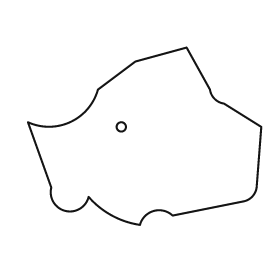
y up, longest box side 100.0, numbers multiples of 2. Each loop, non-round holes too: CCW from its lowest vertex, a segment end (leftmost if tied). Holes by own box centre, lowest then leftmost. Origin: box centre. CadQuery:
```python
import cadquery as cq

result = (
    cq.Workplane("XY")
    .moveTo(-2.0, -38.0)
    .threePointArc((4.0, -32.0), (12.0, -34.0))
    .lineTo(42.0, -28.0)
    .threePointArc((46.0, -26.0), (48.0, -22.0))
    .lineTo(50.0, 4.0)
    .lineTo(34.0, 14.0)
    .threePointArc((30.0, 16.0), (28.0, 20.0))
    .lineTo(18.0, 38.0)
    .lineTo(-4.0, 32.0)
    .lineTo(-20.0, 20.0)
    .threePointArc((-32.0, 6.0), (-50.0, 6.0))
    .lineTo(-40.0, -22.0)
    .threePointArc((-34.0, -32.0), (-24.0, -26.0))
    .threePointArc((-14.0, -34.0), (-2.0, -38.0))
    .close()
    .moveTo(-10.0, 4.0)
    .circle(2.0)
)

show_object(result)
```